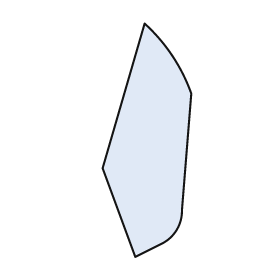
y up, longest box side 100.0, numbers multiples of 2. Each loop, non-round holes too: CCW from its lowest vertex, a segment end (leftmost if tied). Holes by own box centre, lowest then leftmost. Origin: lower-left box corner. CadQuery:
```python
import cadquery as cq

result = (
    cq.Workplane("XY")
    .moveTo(14.0, 0.0)
    .lineTo(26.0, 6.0)
    .threePointArc((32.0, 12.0), (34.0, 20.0))
    .lineTo(38.0, 70.0)
    .threePointArc((30.0, 86.0), (18.0, 100.0))
    .lineTo(0.0, 38.0)
    .close()
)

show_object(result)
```